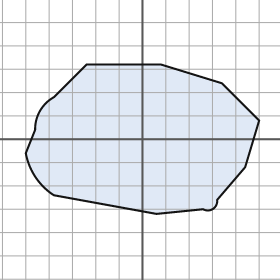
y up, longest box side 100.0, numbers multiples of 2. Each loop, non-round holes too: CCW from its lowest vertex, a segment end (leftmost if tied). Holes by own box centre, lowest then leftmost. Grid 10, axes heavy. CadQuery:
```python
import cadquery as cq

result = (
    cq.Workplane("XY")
    .moveTo(6.0, -32.0)
    .lineTo(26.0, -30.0)
    .threePointArc((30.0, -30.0), (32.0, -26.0))
    .lineTo(44.0, -12.0)
    .lineTo(50.0, 8.0)
    .lineTo(34.0, 24.0)
    .lineTo(8.0, 32.0)
    .lineTo(-24.0, 32.0)
    .lineTo(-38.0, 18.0)
    .threePointArc((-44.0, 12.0), (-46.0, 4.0))
    .lineTo(-50.0, -6.0)
    .threePointArc((-46.0, -16.0), (-38.0, -24.0))
    .close()
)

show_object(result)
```